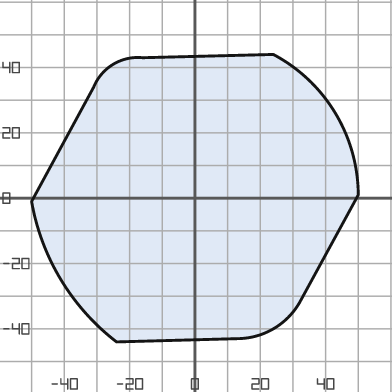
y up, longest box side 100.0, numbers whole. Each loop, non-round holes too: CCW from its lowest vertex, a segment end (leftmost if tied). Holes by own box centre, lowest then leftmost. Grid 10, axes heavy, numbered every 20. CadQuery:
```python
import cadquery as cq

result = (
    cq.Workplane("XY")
    .moveTo(-24.0, -44.0)
    .lineTo(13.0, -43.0)
    .threePointArc((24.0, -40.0), (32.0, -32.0))
    .lineTo(50.0, 1.0)
    .threePointArc((43.0, 26.0), (24.0, 44.0))
    .lineTo(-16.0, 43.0)
    .threePointArc((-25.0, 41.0), (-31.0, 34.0))
    .lineTo(-50.0, -1.0)
    .threePointArc((-41.0, -25.0), (-24.0, -44.0))
    .close()
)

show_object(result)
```